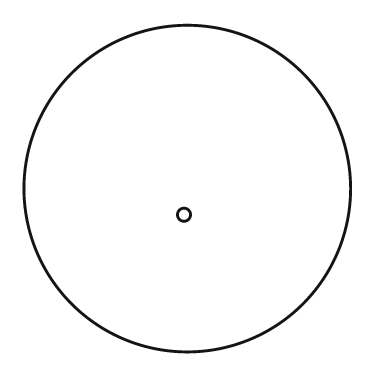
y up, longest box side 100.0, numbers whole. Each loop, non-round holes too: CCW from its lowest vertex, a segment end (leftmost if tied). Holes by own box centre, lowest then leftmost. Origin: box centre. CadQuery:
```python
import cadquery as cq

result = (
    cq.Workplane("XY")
    .moveTo(0.0, 0.0)
    .circle(50.0)
    .moveTo(-1.0, -8.0)
    .circle(2.0)
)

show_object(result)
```